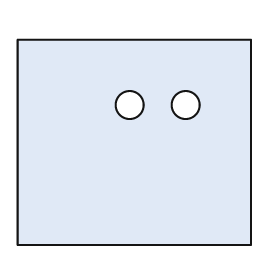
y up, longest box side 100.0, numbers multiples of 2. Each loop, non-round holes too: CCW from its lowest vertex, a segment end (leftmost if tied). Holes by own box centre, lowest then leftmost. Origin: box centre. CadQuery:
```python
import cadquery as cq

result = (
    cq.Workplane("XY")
    .moveTo(-50.0, -44.0)
    .lineTo(50.0, -44.0)
    .lineTo(50.0, 44.0)
    .lineTo(-50.0, 44.0)
    .close()
    .moveTo(-2.0, 16.0)
    .circle(6.0)
    .moveTo(22.0, 16.0)
    .circle(6.0)
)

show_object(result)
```